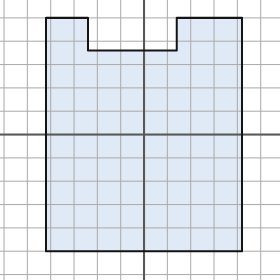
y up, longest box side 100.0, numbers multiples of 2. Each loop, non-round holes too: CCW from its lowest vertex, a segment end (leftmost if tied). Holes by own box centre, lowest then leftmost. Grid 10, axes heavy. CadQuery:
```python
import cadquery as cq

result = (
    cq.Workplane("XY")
    .moveTo(-42.0, -50.0)
    .lineTo(42.0, -50.0)
    .lineTo(42.0, 50.0)
    .lineTo(14.0, 50.0)
    .lineTo(14.0, 36.0)
    .lineTo(-24.0, 36.0)
    .lineTo(-24.0, 50.0)
    .lineTo(-42.0, 50.0)
    .close()
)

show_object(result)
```